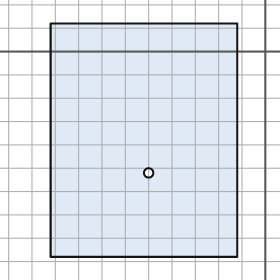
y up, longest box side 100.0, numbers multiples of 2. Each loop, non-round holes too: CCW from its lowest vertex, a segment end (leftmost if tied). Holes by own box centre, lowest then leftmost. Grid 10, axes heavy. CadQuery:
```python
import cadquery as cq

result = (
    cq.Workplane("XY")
    .moveTo(-92.0, -88.0)
    .lineTo(-12.0, -88.0)
    .lineTo(-12.0, 12.0)
    .lineTo(-92.0, 12.0)
    .close()
    .moveTo(-50.0, -52.0)
    .circle(2.0)
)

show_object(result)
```